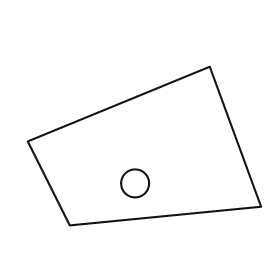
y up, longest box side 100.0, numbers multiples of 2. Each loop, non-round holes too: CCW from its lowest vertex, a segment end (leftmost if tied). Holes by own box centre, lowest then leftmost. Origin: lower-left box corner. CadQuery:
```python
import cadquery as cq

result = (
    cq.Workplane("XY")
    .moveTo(18.0, 0.0)
    .lineTo(100.0, 8.0)
    .lineTo(78.0, 68.0)
    .lineTo(0.0, 36.0)
    .close()
    .moveTo(46.0, 18.0)
    .circle(6.0)
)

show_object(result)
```